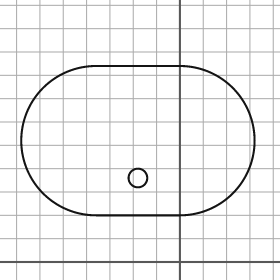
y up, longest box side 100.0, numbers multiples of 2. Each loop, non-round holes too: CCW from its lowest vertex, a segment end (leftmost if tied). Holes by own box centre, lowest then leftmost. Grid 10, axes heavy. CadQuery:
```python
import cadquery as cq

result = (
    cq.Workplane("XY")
    .moveTo(-36.0, 20.0)
    .lineTo(0.0, 20.0)
    .threePointArc((32.0, 52.0), (0.0, 84.0))
    .lineTo(-36.0, 84.0)
    .threePointArc((-68.0, 52.0), (-36.0, 20.0))
    .close()
    .moveTo(-18.0, 36.0)
    .circle(4.0)
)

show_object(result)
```